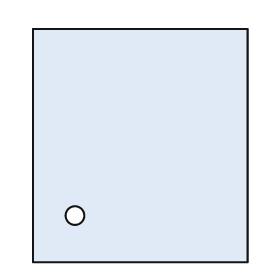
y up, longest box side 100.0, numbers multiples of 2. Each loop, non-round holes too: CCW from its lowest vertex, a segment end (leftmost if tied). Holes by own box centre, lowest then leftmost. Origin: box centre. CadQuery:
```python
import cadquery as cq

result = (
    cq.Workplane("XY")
    .moveTo(-46.0, -50.0)
    .lineTo(46.0, -50.0)
    .lineTo(46.0, 50.0)
    .lineTo(-46.0, 50.0)
    .close()
    .moveTo(-28.0, -30.0)
    .circle(4.0)
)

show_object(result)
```